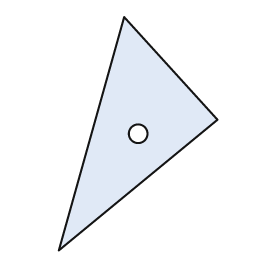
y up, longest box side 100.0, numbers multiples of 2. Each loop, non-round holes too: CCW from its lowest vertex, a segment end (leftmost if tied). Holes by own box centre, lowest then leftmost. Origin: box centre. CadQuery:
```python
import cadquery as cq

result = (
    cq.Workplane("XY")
    .moveTo(-34.0, -50.0)
    .lineTo(34.0, 6.0)
    .lineTo(-6.0, 50.0)
    .close()
    .moveTo(0.0, 0.0)
    .circle(4.0)
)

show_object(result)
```